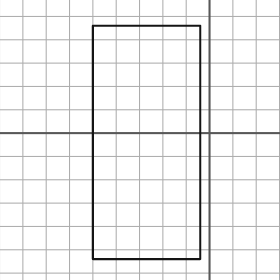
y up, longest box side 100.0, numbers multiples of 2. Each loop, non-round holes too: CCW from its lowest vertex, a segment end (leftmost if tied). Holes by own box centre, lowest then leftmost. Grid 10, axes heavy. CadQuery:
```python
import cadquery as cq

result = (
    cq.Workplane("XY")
    .moveTo(-50.0, -54.0)
    .lineTo(-4.0, -54.0)
    .lineTo(-4.0, 46.0)
    .lineTo(-50.0, 46.0)
    .close()
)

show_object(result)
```